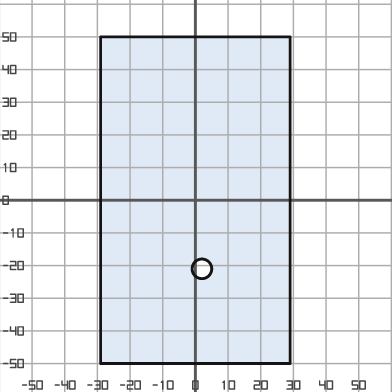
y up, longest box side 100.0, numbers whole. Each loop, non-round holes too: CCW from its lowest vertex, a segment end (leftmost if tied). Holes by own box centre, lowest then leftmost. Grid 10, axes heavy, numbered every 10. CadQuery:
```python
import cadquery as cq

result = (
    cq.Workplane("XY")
    .moveTo(-29.0, -50.0)
    .lineTo(29.0, -50.0)
    .lineTo(29.0, 50.0)
    .lineTo(-29.0, 50.0)
    .close()
    .moveTo(2.0, -21.0)
    .circle(3.0)
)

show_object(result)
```